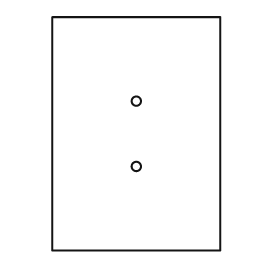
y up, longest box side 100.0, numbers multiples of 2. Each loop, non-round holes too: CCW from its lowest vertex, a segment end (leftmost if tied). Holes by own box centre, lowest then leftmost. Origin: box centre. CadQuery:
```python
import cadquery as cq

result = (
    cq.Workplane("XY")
    .moveTo(-36.0, -50.0)
    .lineTo(36.0, -50.0)
    .lineTo(36.0, 50.0)
    .lineTo(-36.0, 50.0)
    .close()
    .moveTo(0.0, -14.0)
    .circle(2.0)
    .moveTo(0.0, 14.0)
    .circle(2.0)
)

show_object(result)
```